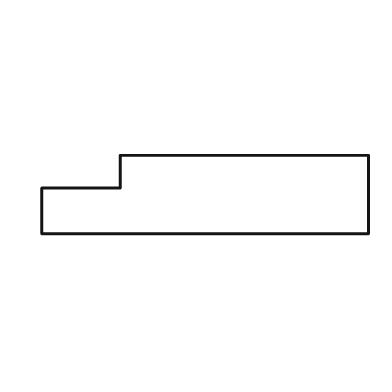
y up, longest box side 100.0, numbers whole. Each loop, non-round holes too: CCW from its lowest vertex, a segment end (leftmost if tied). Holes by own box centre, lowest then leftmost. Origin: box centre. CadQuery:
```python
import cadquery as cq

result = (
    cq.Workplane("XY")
    .moveTo(-50.0, -12.0)
    .lineTo(50.0, -12.0)
    .lineTo(50.0, 12.0)
    .lineTo(-26.0, 12.0)
    .lineTo(-26.0, 2.0)
    .lineTo(-50.0, 2.0)
    .close()
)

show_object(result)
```